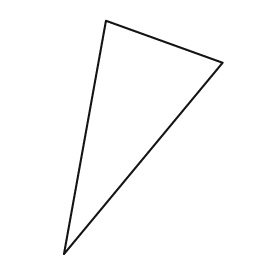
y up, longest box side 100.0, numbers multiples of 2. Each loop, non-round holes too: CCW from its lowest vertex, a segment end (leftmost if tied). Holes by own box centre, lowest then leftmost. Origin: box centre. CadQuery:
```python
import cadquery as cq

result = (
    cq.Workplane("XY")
    .moveTo(-34.0, -50.0)
    .lineTo(34.0, 32.0)
    .lineTo(-16.0, 50.0)
    .close()
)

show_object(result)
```